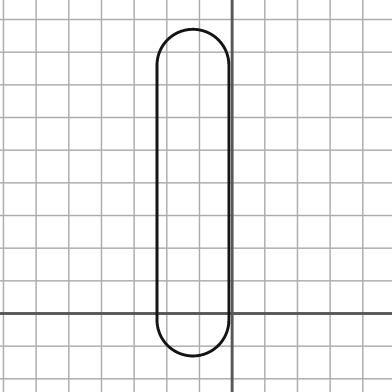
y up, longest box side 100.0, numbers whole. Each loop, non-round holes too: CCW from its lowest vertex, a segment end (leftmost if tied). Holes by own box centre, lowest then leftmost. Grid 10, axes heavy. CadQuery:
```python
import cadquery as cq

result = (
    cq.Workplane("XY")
    .moveTo(-23.0, -2.0)
    .threePointArc((-12.0, -13.0), (-1.0, -2.0))
    .lineTo(-1.0, 76.0)
    .threePointArc((-12.0, 87.0), (-23.0, 76.0))
    .close()
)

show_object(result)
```